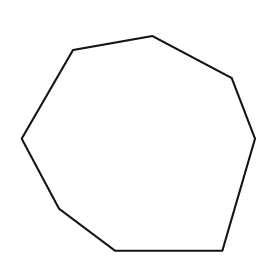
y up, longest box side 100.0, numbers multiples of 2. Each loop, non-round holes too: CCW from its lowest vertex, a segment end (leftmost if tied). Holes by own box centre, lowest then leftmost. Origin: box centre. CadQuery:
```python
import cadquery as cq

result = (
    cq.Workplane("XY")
    .moveTo(-10.0, -46.0)
    .lineTo(36.0, -46.0)
    .lineTo(50.0, 2.0)
    .lineTo(40.0, 28.0)
    .lineTo(6.0, 46.0)
    .lineTo(-28.0, 40.0)
    .lineTo(-50.0, 2.0)
    .lineTo(-34.0, -28.0)
    .close()
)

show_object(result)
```